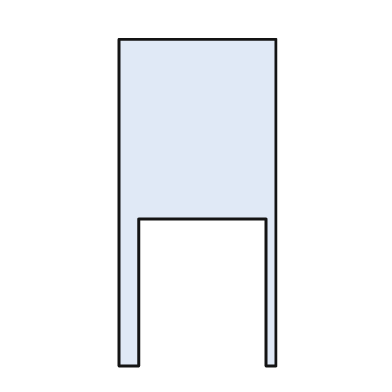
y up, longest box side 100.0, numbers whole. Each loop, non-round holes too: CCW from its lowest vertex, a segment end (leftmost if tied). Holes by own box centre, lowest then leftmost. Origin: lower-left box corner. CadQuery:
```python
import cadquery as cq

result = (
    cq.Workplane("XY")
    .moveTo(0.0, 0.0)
    .lineTo(6.0, 0.0)
    .lineTo(6.0, 45.0)
    .lineTo(45.0, 45.0)
    .lineTo(45.0, 0.0)
    .lineTo(48.0, 0.0)
    .lineTo(48.0, 100.0)
    .lineTo(0.0, 100.0)
    .close()
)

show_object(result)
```